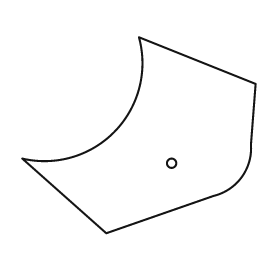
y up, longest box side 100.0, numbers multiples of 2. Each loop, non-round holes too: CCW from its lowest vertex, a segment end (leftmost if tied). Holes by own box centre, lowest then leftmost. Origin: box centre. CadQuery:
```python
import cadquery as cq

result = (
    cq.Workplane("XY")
    .moveTo(-14.0, -42.0)
    .lineTo(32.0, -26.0)
    .threePointArc((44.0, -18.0), (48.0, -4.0))
    .lineTo(50.0, 22.0)
    .lineTo(0.0, 42.0)
    .threePointArc((-10.0, 2.0), (-50.0, -10.0))
    .close()
    .moveTo(14.0, -12.0)
    .circle(2.0)
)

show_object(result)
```